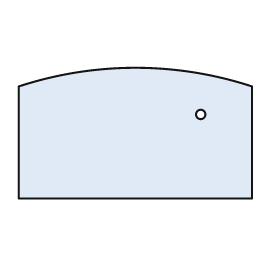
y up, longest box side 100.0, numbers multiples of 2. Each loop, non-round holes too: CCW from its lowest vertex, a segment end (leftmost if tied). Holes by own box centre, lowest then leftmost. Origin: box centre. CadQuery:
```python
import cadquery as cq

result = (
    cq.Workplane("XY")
    .moveTo(-50.0, -28.0)
    .lineTo(50.0, -28.0)
    .lineTo(50.0, 20.0)
    .threePointArc((0.0, 28.0), (-50.0, 20.0))
    .close()
    .moveTo(28.0, 8.0)
    .circle(2.0)
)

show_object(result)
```